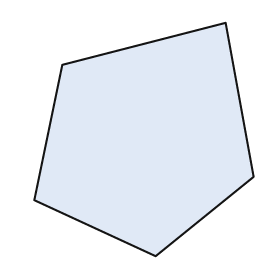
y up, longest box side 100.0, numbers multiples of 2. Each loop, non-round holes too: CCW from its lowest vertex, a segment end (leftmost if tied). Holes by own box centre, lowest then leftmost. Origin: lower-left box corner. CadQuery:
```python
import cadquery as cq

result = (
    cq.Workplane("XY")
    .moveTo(52.0, 0.0)
    .lineTo(94.0, 34.0)
    .lineTo(82.0, 100.0)
    .lineTo(12.0, 82.0)
    .lineTo(0.0, 24.0)
    .close()
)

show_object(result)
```